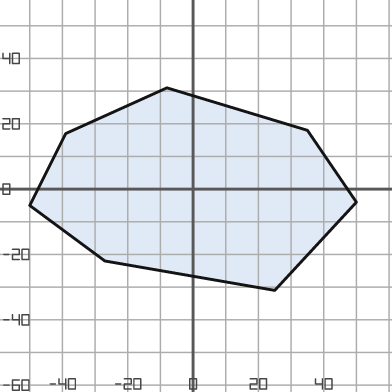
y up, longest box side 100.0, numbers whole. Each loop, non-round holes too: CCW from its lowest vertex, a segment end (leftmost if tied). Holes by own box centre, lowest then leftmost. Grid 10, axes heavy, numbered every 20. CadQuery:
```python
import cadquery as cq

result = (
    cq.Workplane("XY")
    .moveTo(25.0, -31.0)
    .lineTo(50.0, -4.0)
    .lineTo(35.0, 18.0)
    .lineTo(-8.0, 31.0)
    .lineTo(-39.0, 17.0)
    .lineTo(-50.0, -5.0)
    .lineTo(-27.0, -22.0)
    .close()
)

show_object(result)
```